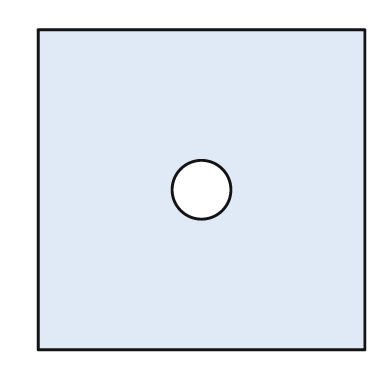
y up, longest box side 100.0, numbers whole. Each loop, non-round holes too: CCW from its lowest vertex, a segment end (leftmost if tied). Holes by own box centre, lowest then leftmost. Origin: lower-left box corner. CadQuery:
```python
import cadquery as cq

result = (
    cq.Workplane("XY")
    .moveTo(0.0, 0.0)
    .lineTo(100.0, 0.0)
    .lineTo(100.0, 98.0)
    .lineTo(0.0, 98.0)
    .close()
    .moveTo(50.0, 49.0)
    .circle(9.0)
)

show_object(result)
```